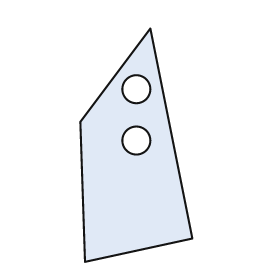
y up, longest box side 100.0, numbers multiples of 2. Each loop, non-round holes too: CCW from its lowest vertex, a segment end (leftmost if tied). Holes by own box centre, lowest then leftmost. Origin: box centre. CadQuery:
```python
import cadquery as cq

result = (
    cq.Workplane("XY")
    .moveTo(-22.0, -50.0)
    .lineTo(24.0, -40.0)
    .lineTo(6.0, 50.0)
    .lineTo(-24.0, 10.0)
    .close()
    .moveTo(0.0, 2.0)
    .circle(6.0)
    .moveTo(0.0, 24.0)
    .circle(6.0)
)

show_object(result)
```